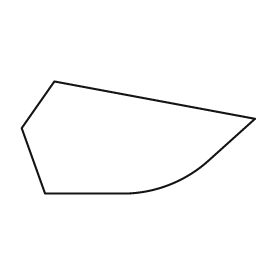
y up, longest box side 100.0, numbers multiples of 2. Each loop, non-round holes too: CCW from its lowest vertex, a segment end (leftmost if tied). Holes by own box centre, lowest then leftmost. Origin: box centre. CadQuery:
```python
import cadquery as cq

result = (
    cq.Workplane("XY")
    .moveTo(-40.0, -24.0)
    .lineTo(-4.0, -24.0)
    .threePointArc((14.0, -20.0), (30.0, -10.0))
    .lineTo(50.0, 8.0)
    .lineTo(-36.0, 24.0)
    .lineTo(-50.0, 4.0)
    .close()
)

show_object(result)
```